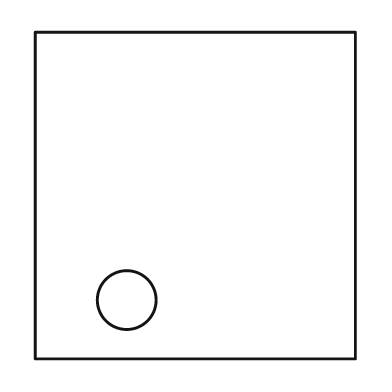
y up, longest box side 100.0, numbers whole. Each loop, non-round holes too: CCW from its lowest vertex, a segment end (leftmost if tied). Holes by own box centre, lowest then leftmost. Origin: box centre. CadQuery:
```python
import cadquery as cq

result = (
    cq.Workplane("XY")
    .moveTo(-49.0, -50.0)
    .lineTo(49.0, -50.0)
    .lineTo(49.0, 50.0)
    .lineTo(-49.0, 50.0)
    .close()
    .moveTo(-21.0, -32.0)
    .circle(9.0)
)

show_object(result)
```